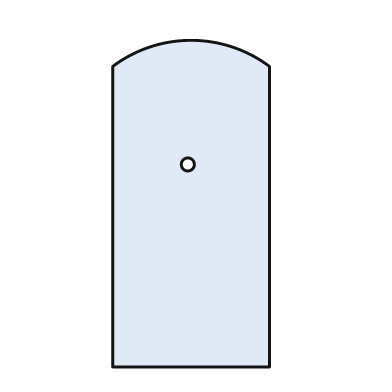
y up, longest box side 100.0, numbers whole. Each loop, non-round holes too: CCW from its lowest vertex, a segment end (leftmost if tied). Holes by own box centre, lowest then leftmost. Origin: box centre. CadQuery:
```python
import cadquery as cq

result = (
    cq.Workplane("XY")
    .moveTo(-24.0, -50.0)
    .lineTo(24.0, -50.0)
    .lineTo(24.0, 42.0)
    .threePointArc((0.0, 50.0), (-24.0, 42.0))
    .close()
    .moveTo(-1.0, 12.0)
    .circle(2.0)
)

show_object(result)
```